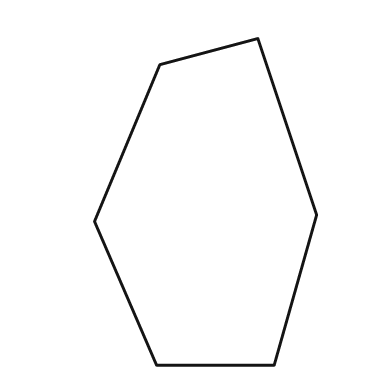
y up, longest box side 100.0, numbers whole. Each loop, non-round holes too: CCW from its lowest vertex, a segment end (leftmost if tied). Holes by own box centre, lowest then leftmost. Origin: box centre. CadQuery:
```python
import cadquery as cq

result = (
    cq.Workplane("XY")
    .moveTo(-15.0, -50.0)
    .lineTo(21.0, -50.0)
    .lineTo(34.0, -4.0)
    .lineTo(16.0, 50.0)
    .lineTo(-14.0, 42.0)
    .lineTo(-34.0, -6.0)
    .close()
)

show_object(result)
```